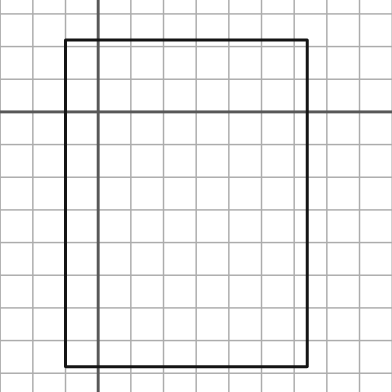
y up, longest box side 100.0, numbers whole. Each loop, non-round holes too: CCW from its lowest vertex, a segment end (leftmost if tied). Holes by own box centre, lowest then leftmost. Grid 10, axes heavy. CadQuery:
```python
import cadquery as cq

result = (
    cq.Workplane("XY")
    .moveTo(-10.0, -78.0)
    .lineTo(64.0, -78.0)
    .lineTo(64.0, 22.0)
    .lineTo(-10.0, 22.0)
    .close()
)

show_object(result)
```